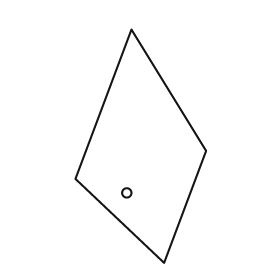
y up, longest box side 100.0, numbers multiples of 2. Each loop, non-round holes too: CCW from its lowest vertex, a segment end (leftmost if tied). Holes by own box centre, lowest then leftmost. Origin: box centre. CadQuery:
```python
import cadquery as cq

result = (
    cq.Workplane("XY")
    .moveTo(10.0, -50.0)
    .lineTo(28.0, -2.0)
    .lineTo(-4.0, 50.0)
    .lineTo(-28.0, -14.0)
    .close()
    .moveTo(-6.0, -20.0)
    .circle(2.0)
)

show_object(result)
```